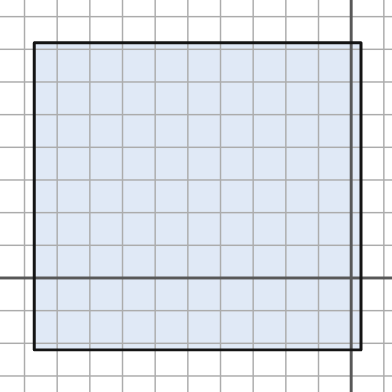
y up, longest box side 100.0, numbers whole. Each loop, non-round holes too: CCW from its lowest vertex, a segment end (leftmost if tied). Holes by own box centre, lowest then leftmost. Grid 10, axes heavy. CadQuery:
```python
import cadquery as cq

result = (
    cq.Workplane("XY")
    .moveTo(-97.0, -22.0)
    .lineTo(3.0, -22.0)
    .lineTo(3.0, 72.0)
    .lineTo(-97.0, 72.0)
    .close()
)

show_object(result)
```